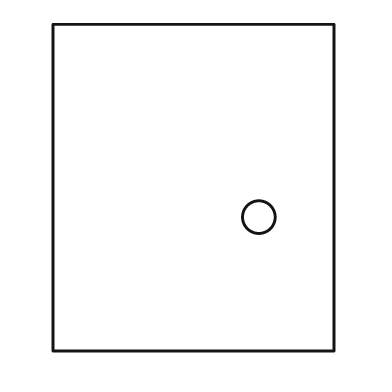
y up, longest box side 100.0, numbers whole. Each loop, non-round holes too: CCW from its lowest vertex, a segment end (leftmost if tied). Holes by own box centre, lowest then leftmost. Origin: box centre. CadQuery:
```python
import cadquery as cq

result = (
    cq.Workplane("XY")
    .moveTo(-43.0, -50.0)
    .lineTo(43.0, -50.0)
    .lineTo(43.0, 50.0)
    .lineTo(-43.0, 50.0)
    .close()
    .moveTo(20.0, -9.0)
    .circle(5.0)
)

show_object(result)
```